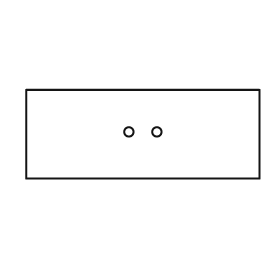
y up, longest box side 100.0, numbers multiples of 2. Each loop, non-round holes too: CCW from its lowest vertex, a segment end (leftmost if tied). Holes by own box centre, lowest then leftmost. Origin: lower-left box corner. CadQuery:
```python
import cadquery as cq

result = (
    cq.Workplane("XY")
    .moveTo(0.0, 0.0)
    .lineTo(100.0, 0.0)
    .lineTo(100.0, 38.0)
    .lineTo(0.0, 38.0)
    .close()
    .moveTo(44.0, 20.0)
    .circle(2.0)
    .moveTo(56.0, 20.0)
    .circle(2.0)
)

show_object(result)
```